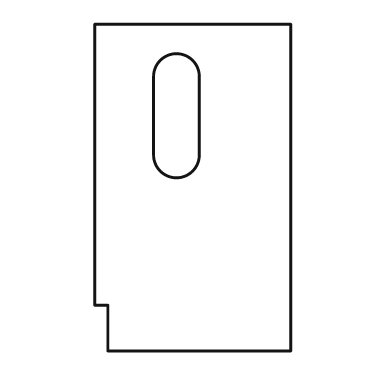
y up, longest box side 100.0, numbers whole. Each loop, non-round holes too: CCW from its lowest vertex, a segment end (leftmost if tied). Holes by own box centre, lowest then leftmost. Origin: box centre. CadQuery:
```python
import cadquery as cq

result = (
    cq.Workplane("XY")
    .moveTo(-26.0, -50.0)
    .lineTo(30.0, -50.0)
    .lineTo(30.0, 50.0)
    .lineTo(-30.0, 50.0)
    .lineTo(-30.0, -36.0)
    .lineTo(-26.0, -36.0)
    .close()
    .moveTo(-12.0, 10.0)
    .threePointArc((-5.0, 3.0), (2.0, 10.0))
    .lineTo(2.0, 34.0)
    .threePointArc((-5.0, 41.0), (-12.0, 34.0))
    .close()
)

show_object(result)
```